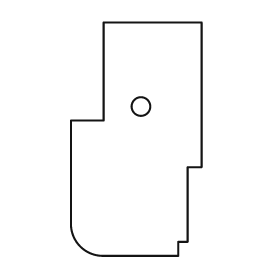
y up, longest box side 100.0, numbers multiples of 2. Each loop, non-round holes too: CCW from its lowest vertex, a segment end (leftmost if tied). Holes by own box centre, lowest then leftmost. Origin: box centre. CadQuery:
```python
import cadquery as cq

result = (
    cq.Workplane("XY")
    .moveTo(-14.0, -50.0)
    .lineTo(18.0, -50.0)
    .lineTo(18.0, -44.0)
    .lineTo(22.0, -44.0)
    .lineTo(22.0, -12.0)
    .lineTo(28.0, -12.0)
    .lineTo(28.0, 50.0)
    .lineTo(-14.0, 50.0)
    .lineTo(-14.0, 8.0)
    .lineTo(-28.0, 8.0)
    .lineTo(-28.0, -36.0)
    .threePointArc((-24.0, -46.0), (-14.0, -50.0))
    .close()
    .moveTo(2.0, 14.0)
    .circle(4.0)
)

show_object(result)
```